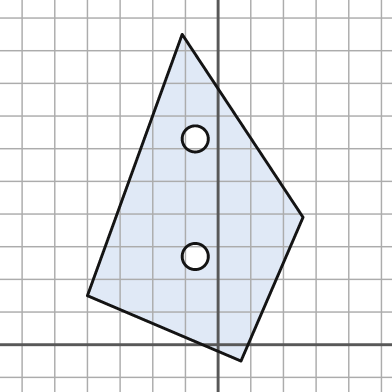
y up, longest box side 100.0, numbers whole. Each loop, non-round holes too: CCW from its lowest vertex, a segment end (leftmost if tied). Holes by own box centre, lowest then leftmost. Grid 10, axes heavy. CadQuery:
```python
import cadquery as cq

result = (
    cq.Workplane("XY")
    .moveTo(7.0, -5.0)
    .lineTo(26.0, 39.0)
    .lineTo(-11.0, 95.0)
    .lineTo(-40.0, 15.0)
    .close()
    .moveTo(-7.0, 27.0)
    .circle(4.0)
    .moveTo(-7.0, 63.0)
    .circle(4.0)
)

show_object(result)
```